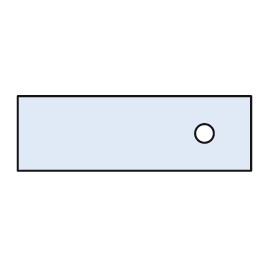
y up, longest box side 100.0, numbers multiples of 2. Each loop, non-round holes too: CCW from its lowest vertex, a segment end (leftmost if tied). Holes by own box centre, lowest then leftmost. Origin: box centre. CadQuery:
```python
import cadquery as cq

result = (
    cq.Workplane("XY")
    .moveTo(-50.0, -16.0)
    .lineTo(50.0, -16.0)
    .lineTo(50.0, 16.0)
    .lineTo(-50.0, 16.0)
    .close()
    .moveTo(30.0, 0.0)
    .circle(4.0)
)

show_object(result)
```